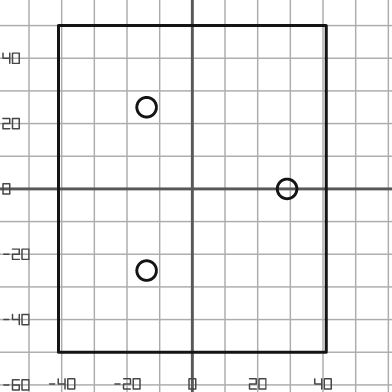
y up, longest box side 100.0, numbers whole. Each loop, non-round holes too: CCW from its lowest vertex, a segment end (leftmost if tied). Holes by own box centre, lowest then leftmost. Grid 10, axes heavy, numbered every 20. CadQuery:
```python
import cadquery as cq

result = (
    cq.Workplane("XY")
    .moveTo(-41.0, -50.0)
    .lineTo(41.0, -50.0)
    .lineTo(41.0, 50.0)
    .lineTo(-41.0, 50.0)
    .close()
    .moveTo(-14.0, -25.0)
    .circle(3.0)
    .moveTo(29.0, 0.0)
    .circle(3.0)
    .moveTo(-14.0, 25.0)
    .circle(3.0)
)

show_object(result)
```